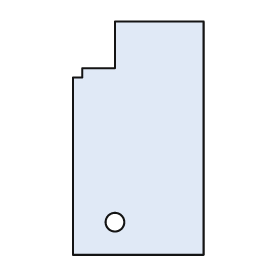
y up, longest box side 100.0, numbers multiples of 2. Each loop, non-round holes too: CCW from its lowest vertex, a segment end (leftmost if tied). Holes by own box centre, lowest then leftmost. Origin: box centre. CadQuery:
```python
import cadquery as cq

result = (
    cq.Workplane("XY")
    .moveTo(-28.0, -50.0)
    .lineTo(28.0, -50.0)
    .lineTo(28.0, 50.0)
    .lineTo(-10.0, 50.0)
    .lineTo(-10.0, 30.0)
    .lineTo(-24.0, 30.0)
    .lineTo(-24.0, 26.0)
    .lineTo(-28.0, 26.0)
    .close()
    .moveTo(-10.0, -36.0)
    .circle(4.0)
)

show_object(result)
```